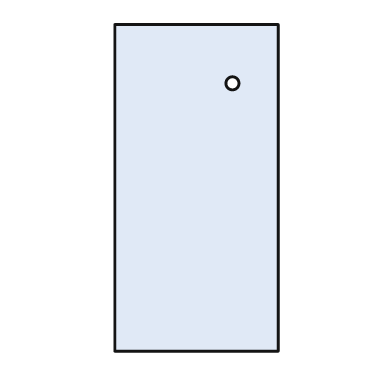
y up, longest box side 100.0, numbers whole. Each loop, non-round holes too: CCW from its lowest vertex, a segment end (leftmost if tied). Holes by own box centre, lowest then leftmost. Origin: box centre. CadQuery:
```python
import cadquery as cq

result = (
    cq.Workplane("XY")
    .moveTo(-25.0, -50.0)
    .lineTo(25.0, -50.0)
    .lineTo(25.0, 50.0)
    .lineTo(-25.0, 50.0)
    .close()
    .moveTo(11.0, 32.0)
    .circle(2.0)
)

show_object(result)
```